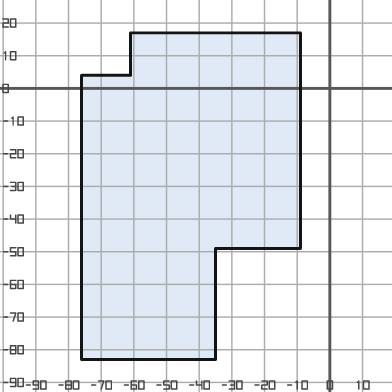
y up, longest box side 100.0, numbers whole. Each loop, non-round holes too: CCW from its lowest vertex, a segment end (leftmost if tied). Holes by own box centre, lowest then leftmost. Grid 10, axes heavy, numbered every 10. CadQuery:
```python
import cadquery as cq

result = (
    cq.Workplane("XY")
    .moveTo(-76.0, -83.0)
    .lineTo(-35.0, -83.0)
    .lineTo(-35.0, -49.0)
    .lineTo(-9.0, -49.0)
    .lineTo(-9.0, 17.0)
    .lineTo(-61.0, 17.0)
    .lineTo(-61.0, 4.0)
    .lineTo(-76.0, 4.0)
    .close()
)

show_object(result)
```